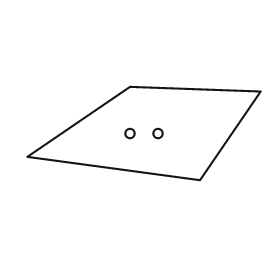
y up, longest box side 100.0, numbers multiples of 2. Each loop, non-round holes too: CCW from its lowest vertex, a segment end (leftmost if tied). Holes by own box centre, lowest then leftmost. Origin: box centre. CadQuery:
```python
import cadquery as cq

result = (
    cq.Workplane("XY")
    .moveTo(24.0, -20.0)
    .lineTo(50.0, 18.0)
    .lineTo(-6.0, 20.0)
    .lineTo(-50.0, -10.0)
    .close()
    .moveTo(-6.0, 0.0)
    .circle(2.0)
    .moveTo(6.0, 0.0)
    .circle(2.0)
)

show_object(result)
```